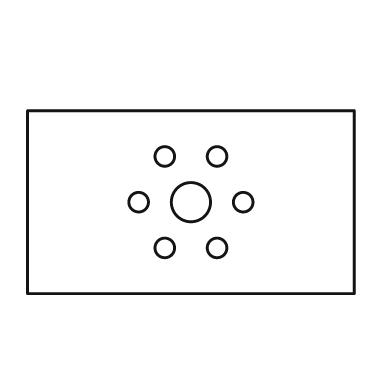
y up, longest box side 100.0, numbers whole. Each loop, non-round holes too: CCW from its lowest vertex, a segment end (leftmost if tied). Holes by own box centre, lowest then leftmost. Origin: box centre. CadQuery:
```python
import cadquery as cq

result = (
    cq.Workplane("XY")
    .moveTo(-50.0, -28.0)
    .lineTo(50.0, -28.0)
    .lineTo(50.0, 28.0)
    .lineTo(-50.0, 28.0)
    .close()
    .moveTo(-8.0, -14.0)
    .circle(3.0)
    .moveTo(8.0, -14.0)
    .circle(3.0)
    .moveTo(-16.0, 0.0)
    .circle(3.0)
    .moveTo(0.0, 0.0)
    .circle(6.0)
    .moveTo(16.0, 0.0)
    .circle(3.0)
    .moveTo(-8.0, 14.0)
    .circle(3.0)
    .moveTo(8.0, 14.0)
    .circle(3.0)
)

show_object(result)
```